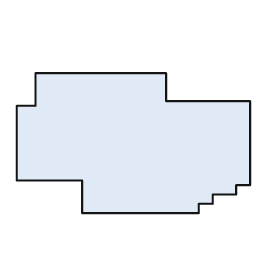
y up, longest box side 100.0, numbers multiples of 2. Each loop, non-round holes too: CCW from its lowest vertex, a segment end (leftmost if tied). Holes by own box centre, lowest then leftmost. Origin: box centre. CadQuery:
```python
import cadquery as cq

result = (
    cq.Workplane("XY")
    .moveTo(-22.0, -30.0)
    .lineTo(28.0, -30.0)
    .lineTo(28.0, -26.0)
    .lineTo(34.0, -26.0)
    .lineTo(34.0, -22.0)
    .lineTo(44.0, -22.0)
    .lineTo(44.0, -18.0)
    .lineTo(50.0, -18.0)
    .lineTo(50.0, 18.0)
    .lineTo(14.0, 18.0)
    .lineTo(14.0, 30.0)
    .lineTo(-42.0, 30.0)
    .lineTo(-42.0, 16.0)
    .lineTo(-50.0, 16.0)
    .lineTo(-50.0, -16.0)
    .lineTo(-22.0, -16.0)
    .close()
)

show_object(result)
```